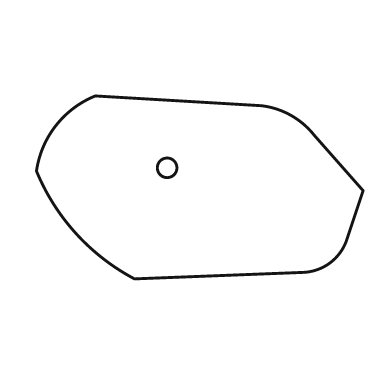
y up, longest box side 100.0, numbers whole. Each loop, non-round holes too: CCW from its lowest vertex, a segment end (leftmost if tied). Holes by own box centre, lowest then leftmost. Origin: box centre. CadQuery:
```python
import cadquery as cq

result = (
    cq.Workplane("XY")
    .moveTo(-20.0, -28.0)
    .lineTo(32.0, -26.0)
    .threePointArc((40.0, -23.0), (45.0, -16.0))
    .lineTo(50.0, -1.0)
    .lineTo(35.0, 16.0)
    .threePointArc((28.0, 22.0), (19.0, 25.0))
    .lineTo(-32.0, 28.0)
    .threePointArc((-44.0, 19.0), (-50.0, 5.0))
    .threePointArc((-38.0, -14.0), (-20.0, -28.0))
    .close()
    .moveTo(-10.0, 6.0)
    .circle(3.0)
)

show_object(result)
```